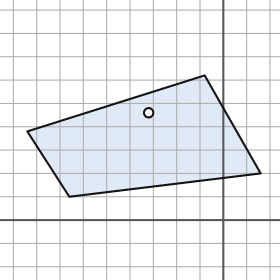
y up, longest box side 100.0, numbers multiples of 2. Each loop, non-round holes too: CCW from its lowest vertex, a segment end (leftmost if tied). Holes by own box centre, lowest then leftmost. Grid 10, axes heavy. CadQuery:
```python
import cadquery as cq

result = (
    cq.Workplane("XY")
    .moveTo(-66.0, 10.0)
    .lineTo(16.0, 20.0)
    .lineTo(-8.0, 62.0)
    .lineTo(-84.0, 38.0)
    .close()
    .moveTo(-32.0, 46.0)
    .circle(2.0)
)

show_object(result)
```